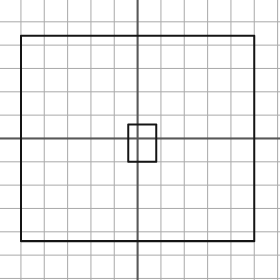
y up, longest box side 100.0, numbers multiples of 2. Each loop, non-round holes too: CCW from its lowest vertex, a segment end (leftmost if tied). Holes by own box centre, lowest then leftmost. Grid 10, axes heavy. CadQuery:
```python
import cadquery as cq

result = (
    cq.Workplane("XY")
    .moveTo(-50.0, -44.0)
    .lineTo(50.0, -44.0)
    .lineTo(50.0, 44.0)
    .lineTo(-50.0, 44.0)
    .close()
    .moveTo(-4.0, -10.0)
    .lineTo(8.0, -10.0)
    .lineTo(8.0, 6.0)
    .lineTo(-4.0, 6.0)
    .close()
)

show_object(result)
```